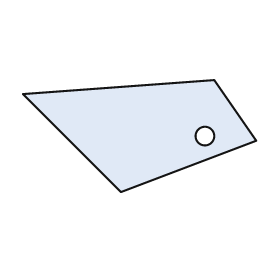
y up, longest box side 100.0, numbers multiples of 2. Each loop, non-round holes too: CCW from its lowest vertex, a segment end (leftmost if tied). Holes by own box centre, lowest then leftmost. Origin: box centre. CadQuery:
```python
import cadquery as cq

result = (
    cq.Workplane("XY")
    .moveTo(-8.0, -24.0)
    .lineTo(50.0, -2.0)
    .lineTo(32.0, 24.0)
    .lineTo(-50.0, 18.0)
    .close()
    .moveTo(28.0, 0.0)
    .circle(4.0)
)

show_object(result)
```